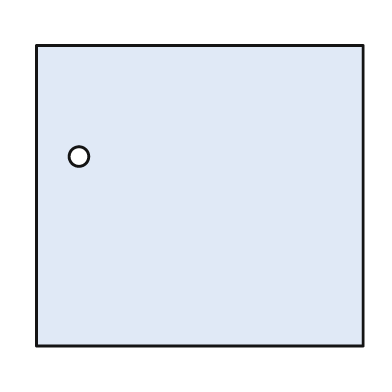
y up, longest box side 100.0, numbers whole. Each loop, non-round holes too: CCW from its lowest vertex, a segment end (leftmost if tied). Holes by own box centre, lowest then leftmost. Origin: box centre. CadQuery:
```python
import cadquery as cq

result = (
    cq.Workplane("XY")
    .moveTo(-50.0, -46.0)
    .lineTo(50.0, -46.0)
    .lineTo(50.0, 46.0)
    .lineTo(-50.0, 46.0)
    .close()
    .moveTo(-37.0, 12.0)
    .circle(3.0)
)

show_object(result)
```